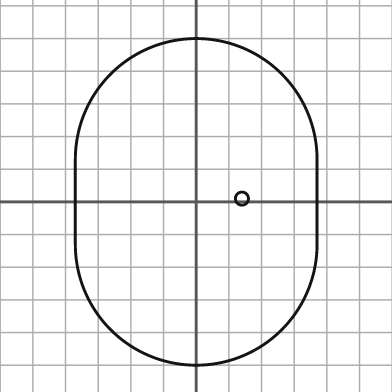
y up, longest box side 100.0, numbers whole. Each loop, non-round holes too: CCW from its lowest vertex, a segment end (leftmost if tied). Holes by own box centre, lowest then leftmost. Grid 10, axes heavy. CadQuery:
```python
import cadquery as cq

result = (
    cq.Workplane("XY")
    .moveTo(-37.0, -13.0)
    .threePointArc((0.0, -50.0), (37.0, -13.0))
    .lineTo(37.0, 13.0)
    .threePointArc((0.0, 50.0), (-37.0, 13.0))
    .close()
    .moveTo(14.0, 1.0)
    .circle(2.0)
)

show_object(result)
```